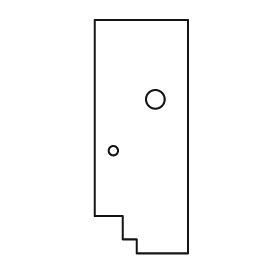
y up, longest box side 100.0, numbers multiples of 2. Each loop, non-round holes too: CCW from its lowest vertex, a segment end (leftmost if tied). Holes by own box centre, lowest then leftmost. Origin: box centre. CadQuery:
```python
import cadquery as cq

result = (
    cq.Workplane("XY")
    .moveTo(-2.0, -50.0)
    .lineTo(20.0, -50.0)
    .lineTo(20.0, 50.0)
    .lineTo(-20.0, 50.0)
    .lineTo(-20.0, -34.0)
    .lineTo(-8.0, -34.0)
    .lineTo(-8.0, -44.0)
    .lineTo(-2.0, -44.0)
    .close()
    .moveTo(-12.0, -6.0)
    .circle(2.0)
    .moveTo(6.0, 16.0)
    .circle(4.0)
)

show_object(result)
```